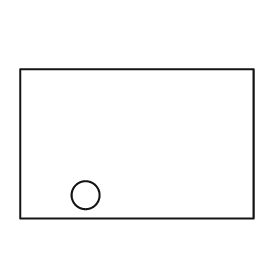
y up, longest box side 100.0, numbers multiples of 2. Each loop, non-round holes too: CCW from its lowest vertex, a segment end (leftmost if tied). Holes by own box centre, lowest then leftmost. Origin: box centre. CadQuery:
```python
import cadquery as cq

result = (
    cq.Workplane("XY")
    .moveTo(-50.0, -32.0)
    .lineTo(50.0, -32.0)
    .lineTo(50.0, 32.0)
    .lineTo(-50.0, 32.0)
    .close()
    .moveTo(-22.0, -22.0)
    .circle(6.0)
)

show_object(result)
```